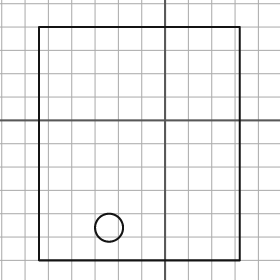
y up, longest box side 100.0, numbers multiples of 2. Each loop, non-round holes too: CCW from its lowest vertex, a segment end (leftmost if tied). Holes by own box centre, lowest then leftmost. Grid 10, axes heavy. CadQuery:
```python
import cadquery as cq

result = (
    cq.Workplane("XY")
    .moveTo(-54.0, -60.0)
    .lineTo(32.0, -60.0)
    .lineTo(32.0, 40.0)
    .lineTo(-54.0, 40.0)
    .close()
    .moveTo(-24.0, -46.0)
    .circle(6.0)
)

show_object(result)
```